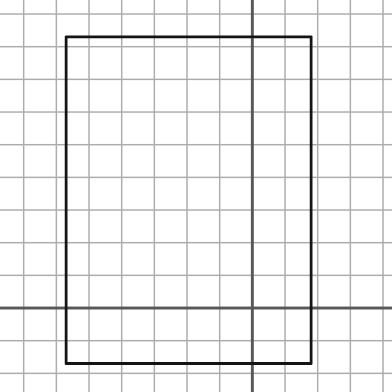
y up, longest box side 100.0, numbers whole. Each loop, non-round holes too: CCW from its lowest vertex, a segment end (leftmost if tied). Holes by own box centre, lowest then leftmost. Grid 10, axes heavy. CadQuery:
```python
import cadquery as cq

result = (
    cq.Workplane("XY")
    .moveTo(-57.0, -17.0)
    .lineTo(18.0, -17.0)
    .lineTo(18.0, 83.0)
    .lineTo(-57.0, 83.0)
    .close()
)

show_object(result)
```